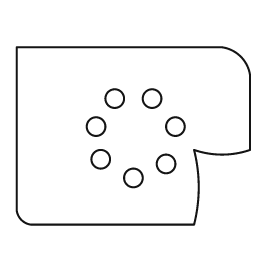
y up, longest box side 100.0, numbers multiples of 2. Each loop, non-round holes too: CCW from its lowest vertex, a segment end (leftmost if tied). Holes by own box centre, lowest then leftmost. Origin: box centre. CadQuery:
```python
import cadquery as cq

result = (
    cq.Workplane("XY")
    .moveTo(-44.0, -38.0)
    .lineTo(26.0, -38.0)
    .threePointArc((28.0, -22.0), (26.0, -6.0))
    .threePointArc((38.0, -8.0), (50.0, -6.0))
    .lineTo(50.0, 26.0)
    .threePointArc((46.0, 34.0), (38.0, 38.0))
    .lineTo(-50.0, 38.0)
    .lineTo(-50.0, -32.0)
    .threePointArc((-48.0, -36.0), (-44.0, -38.0))
    .close()
    .moveTo(0.0, -18.0)
    .circle(4.0)
    .moveTo(14.0, -12.0)
    .circle(4.0)
    .moveTo(-14.0, -10.0)
    .circle(4.0)
    .moveTo(-16.0, 4.0)
    .circle(4.0)
    .moveTo(18.0, 4.0)
    .circle(4.0)
    .moveTo(-8.0, 16.0)
    .circle(4.0)
    .moveTo(8.0, 16.0)
    .circle(4.0)
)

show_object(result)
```